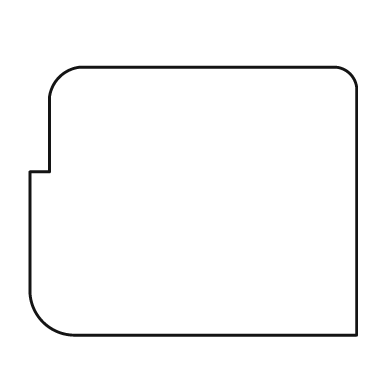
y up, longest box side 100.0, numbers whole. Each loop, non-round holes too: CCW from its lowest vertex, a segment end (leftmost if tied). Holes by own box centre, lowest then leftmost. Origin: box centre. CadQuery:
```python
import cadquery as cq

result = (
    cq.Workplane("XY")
    .moveTo(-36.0, -41.0)
    .lineTo(50.0, -41.0)
    .lineTo(50.0, 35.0)
    .threePointArc((48.0, 39.0), (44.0, 41.0))
    .lineTo(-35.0, 41.0)
    .threePointArc((-41.0, 38.0), (-44.0, 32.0))
    .lineTo(-44.0, 9.0)
    .lineTo(-50.0, 9.0)
    .lineTo(-50.0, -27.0)
    .threePointArc((-46.0, -37.0), (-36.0, -41.0))
    .close()
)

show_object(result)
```